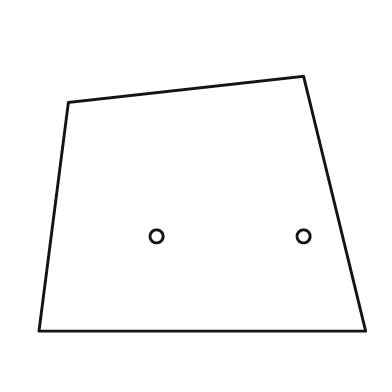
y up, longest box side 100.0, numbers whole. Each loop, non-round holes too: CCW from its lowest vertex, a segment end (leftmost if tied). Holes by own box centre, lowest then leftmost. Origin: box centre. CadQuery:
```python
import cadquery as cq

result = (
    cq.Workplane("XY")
    .moveTo(-50.0, -39.0)
    .lineTo(50.0, -39.0)
    .lineTo(31.0, 39.0)
    .lineTo(-41.0, 31.0)
    .close()
    .moveTo(-14.0, -10.0)
    .circle(2.0)
    .moveTo(31.0, -10.0)
    .circle(2.0)
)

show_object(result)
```